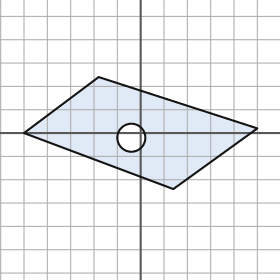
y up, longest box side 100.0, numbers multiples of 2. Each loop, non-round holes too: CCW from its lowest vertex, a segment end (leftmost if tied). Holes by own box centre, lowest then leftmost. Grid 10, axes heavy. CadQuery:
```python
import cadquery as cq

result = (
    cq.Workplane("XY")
    .moveTo(14.0, -24.0)
    .lineTo(50.0, 2.0)
    .lineTo(-18.0, 24.0)
    .lineTo(-50.0, 0.0)
    .close()
    .moveTo(-4.0, -2.0)
    .circle(6.0)
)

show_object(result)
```